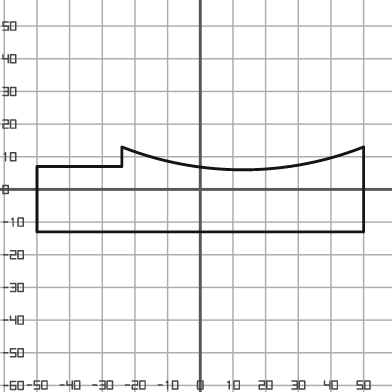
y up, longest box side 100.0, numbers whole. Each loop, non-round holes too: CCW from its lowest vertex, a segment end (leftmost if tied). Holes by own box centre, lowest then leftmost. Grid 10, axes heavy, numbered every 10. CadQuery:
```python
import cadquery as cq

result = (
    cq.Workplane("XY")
    .moveTo(-50.0, -13.0)
    .lineTo(50.0, -13.0)
    .lineTo(50.0, 13.0)
    .threePointArc((13.0, 6.0), (-24.0, 13.0))
    .lineTo(-24.0, 7.0)
    .lineTo(-50.0, 7.0)
    .close()
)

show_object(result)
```